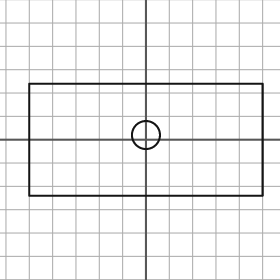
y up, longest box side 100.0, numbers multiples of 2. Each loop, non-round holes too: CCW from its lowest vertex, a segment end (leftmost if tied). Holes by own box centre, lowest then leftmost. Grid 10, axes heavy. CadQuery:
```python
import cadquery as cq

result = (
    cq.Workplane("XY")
    .moveTo(-50.0, -24.0)
    .lineTo(50.0, -24.0)
    .lineTo(50.0, 24.0)
    .lineTo(-50.0, 24.0)
    .close()
    .moveTo(0.0, 2.0)
    .circle(6.0)
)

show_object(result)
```